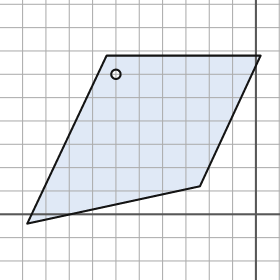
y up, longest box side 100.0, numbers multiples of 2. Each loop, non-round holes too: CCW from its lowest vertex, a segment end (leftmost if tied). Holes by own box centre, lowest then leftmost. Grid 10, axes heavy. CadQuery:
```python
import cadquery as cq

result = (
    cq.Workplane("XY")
    .moveTo(-98.0, -4.0)
    .lineTo(-24.0, 12.0)
    .lineTo(2.0, 68.0)
    .lineTo(-64.0, 68.0)
    .close()
    .moveTo(-60.0, 60.0)
    .circle(2.0)
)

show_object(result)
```